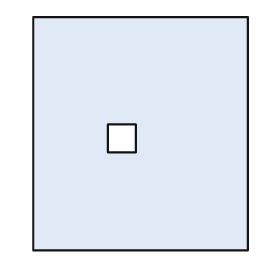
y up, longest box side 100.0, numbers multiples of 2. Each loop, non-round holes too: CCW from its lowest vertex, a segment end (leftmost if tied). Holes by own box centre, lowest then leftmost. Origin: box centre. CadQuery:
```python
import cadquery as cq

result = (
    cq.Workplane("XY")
    .moveTo(-46.0, -50.0)
    .lineTo(46.0, -50.0)
    .lineTo(46.0, 50.0)
    .lineTo(-46.0, 50.0)
    .close()
    .moveTo(-14.0, -8.0)
    .lineTo(-2.0, -8.0)
    .lineTo(-2.0, 4.0)
    .lineTo(-14.0, 4.0)
    .close()
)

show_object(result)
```